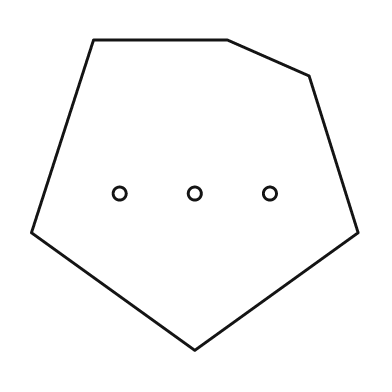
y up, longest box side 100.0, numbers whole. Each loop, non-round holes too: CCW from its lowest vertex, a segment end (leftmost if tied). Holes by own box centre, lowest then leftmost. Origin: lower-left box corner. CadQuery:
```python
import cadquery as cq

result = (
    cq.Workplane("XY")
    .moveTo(50.0, 0.0)
    .lineTo(100.0, 36.0)
    .lineTo(85.0, 84.0)
    .lineTo(60.0, 95.0)
    .lineTo(19.0, 95.0)
    .lineTo(0.0, 36.0)
    .close()
    .moveTo(27.0, 48.0)
    .circle(2.0)
    .moveTo(50.0, 48.0)
    .circle(2.0)
    .moveTo(73.0, 48.0)
    .circle(2.0)
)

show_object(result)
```